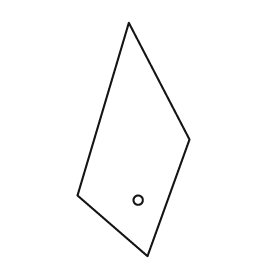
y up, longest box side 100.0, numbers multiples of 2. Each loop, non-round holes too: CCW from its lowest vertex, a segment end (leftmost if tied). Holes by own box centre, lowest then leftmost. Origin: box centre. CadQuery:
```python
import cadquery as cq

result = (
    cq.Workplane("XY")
    .moveTo(6.0, -50.0)
    .lineTo(24.0, 0.0)
    .lineTo(-2.0, 50.0)
    .lineTo(-24.0, -24.0)
    .close()
    .moveTo(2.0, -26.0)
    .circle(2.0)
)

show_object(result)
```